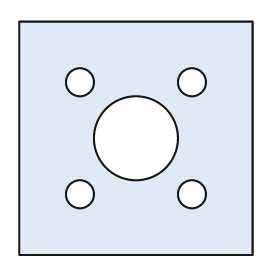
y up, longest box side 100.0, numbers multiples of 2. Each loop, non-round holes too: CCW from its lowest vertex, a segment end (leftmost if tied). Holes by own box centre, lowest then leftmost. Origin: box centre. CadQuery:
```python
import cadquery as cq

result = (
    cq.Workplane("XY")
    .moveTo(-50.0, -50.0)
    .lineTo(50.0, -50.0)
    .lineTo(50.0, 50.0)
    .lineTo(-50.0, 50.0)
    .close()
    .moveTo(-24.0, -24.0)
    .circle(6.0)
    .moveTo(24.0, -24.0)
    .circle(6.0)
    .moveTo(0.0, 0.0)
    .circle(18.0)
    .moveTo(-24.0, 24.0)
    .circle(6.0)
    .moveTo(24.0, 24.0)
    .circle(6.0)
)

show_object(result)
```